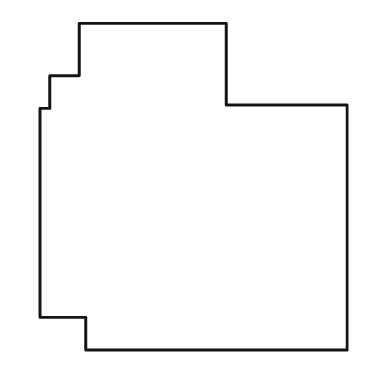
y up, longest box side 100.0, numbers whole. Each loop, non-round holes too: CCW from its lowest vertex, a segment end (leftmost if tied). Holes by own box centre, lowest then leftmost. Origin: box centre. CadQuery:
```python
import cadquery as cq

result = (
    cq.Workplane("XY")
    .moveTo(-33.0, -50.0)
    .lineTo(47.0, -50.0)
    .lineTo(47.0, 25.0)
    .lineTo(10.0, 25.0)
    .lineTo(10.0, 50.0)
    .lineTo(-35.0, 50.0)
    .lineTo(-35.0, 34.0)
    .lineTo(-44.0, 34.0)
    .lineTo(-44.0, 24.0)
    .lineTo(-47.0, 24.0)
    .lineTo(-47.0, -40.0)
    .lineTo(-33.0, -40.0)
    .close()
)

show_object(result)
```